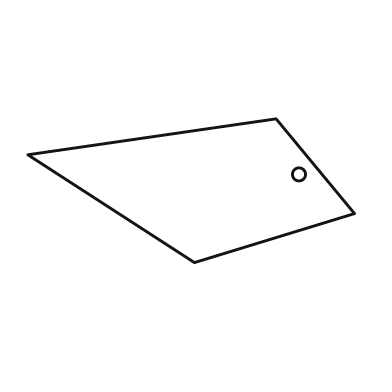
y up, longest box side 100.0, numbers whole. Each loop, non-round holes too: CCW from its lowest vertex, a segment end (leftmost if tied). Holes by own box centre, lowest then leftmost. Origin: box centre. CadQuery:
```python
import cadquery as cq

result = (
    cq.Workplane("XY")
    .moveTo(1.0, -22.0)
    .lineTo(50.0, -7.0)
    .lineTo(26.0, 22.0)
    .lineTo(-50.0, 11.0)
    .close()
    .moveTo(33.0, 5.0)
    .circle(2.0)
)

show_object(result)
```